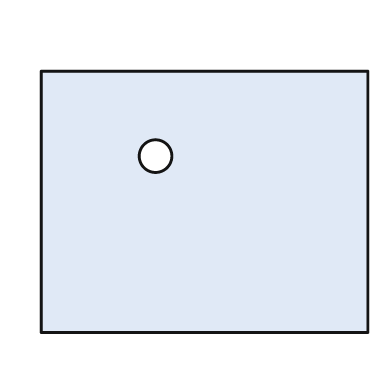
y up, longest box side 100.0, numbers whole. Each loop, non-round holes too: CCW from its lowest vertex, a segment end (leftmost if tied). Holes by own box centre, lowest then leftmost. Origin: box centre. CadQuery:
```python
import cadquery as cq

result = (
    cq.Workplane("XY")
    .moveTo(-50.0, -40.0)
    .lineTo(50.0, -40.0)
    .lineTo(50.0, 40.0)
    .lineTo(-50.0, 40.0)
    .close()
    .moveTo(-15.0, 14.0)
    .circle(5.0)
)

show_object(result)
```